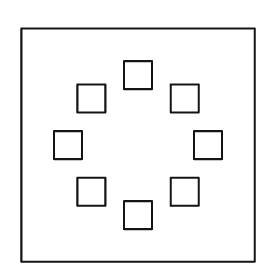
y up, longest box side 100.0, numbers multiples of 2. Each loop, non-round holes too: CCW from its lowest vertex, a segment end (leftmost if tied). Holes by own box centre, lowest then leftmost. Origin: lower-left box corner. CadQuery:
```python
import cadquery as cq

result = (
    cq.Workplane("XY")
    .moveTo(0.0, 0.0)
    .lineTo(100.0, 0.0)
    .lineTo(100.0, 100.0)
    .lineTo(0.0, 100.0)
    .close()
    .moveTo(44.0, 14.0)
    .lineTo(56.0, 14.0)
    .lineTo(56.0, 26.0)
    .lineTo(44.0, 26.0)
    .close()
    .moveTo(24.0, 24.0)
    .lineTo(36.0, 24.0)
    .lineTo(36.0, 36.0)
    .lineTo(24.0, 36.0)
    .close()
    .moveTo(64.0, 24.0)
    .lineTo(76.0, 24.0)
    .lineTo(76.0, 36.0)
    .lineTo(64.0, 36.0)
    .close()
    .moveTo(14.0, 44.0)
    .lineTo(26.0, 44.0)
    .lineTo(26.0, 56.0)
    .lineTo(14.0, 56.0)
    .close()
    .moveTo(74.0, 44.0)
    .lineTo(86.0, 44.0)
    .lineTo(86.0, 56.0)
    .lineTo(74.0, 56.0)
    .close()
    .moveTo(24.0, 64.0)
    .lineTo(36.0, 64.0)
    .lineTo(36.0, 76.0)
    .lineTo(24.0, 76.0)
    .close()
    .moveTo(64.0, 64.0)
    .lineTo(76.0, 64.0)
    .lineTo(76.0, 76.0)
    .lineTo(64.0, 76.0)
    .close()
    .moveTo(44.0, 74.0)
    .lineTo(56.0, 74.0)
    .lineTo(56.0, 86.0)
    .lineTo(44.0, 86.0)
    .close()
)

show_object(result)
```